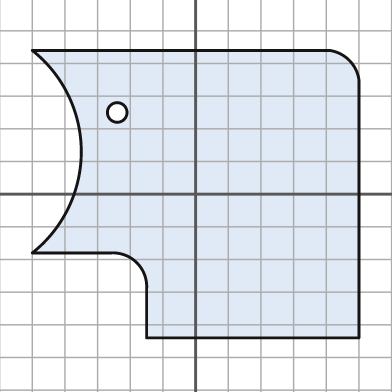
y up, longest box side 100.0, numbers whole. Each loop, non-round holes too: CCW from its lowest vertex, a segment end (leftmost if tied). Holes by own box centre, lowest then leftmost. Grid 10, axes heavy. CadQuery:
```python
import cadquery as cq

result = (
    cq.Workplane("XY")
    .moveTo(-15.0, -44.0)
    .lineTo(50.0, -44.0)
    .lineTo(50.0, 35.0)
    .threePointArc((47.0, 41.0), (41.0, 44.0))
    .lineTo(-50.0, 44.0)
    .threePointArc((-35.0, 13.0), (-50.0, -18.0))
    .lineTo(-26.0, -18.0)
    .threePointArc((-18.0, -21.0), (-15.0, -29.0))
    .close()
    .moveTo(-24.0, 25.0)
    .circle(3.0)
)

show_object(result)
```